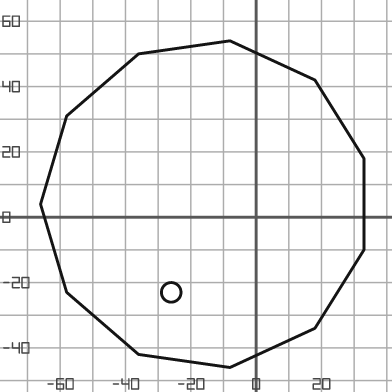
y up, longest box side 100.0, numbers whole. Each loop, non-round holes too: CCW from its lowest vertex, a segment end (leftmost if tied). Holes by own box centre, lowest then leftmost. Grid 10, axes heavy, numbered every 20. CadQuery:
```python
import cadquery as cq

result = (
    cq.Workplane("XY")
    .moveTo(-8.0, -46.0)
    .lineTo(18.0, -34.0)
    .lineTo(33.0, -10.0)
    .lineTo(33.0, 18.0)
    .lineTo(18.0, 42.0)
    .lineTo(-8.0, 54.0)
    .lineTo(-36.0, 50.0)
    .lineTo(-58.0, 31.0)
    .lineTo(-66.0, 4.0)
    .lineTo(-58.0, -23.0)
    .lineTo(-36.0, -42.0)
    .close()
    .moveTo(-26.0, -23.0)
    .circle(3.0)
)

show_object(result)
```